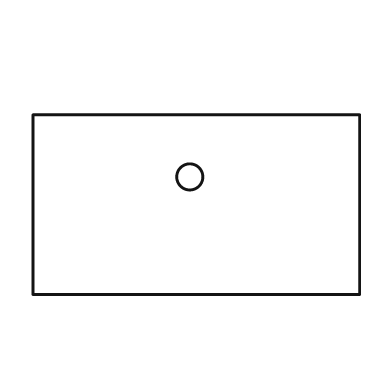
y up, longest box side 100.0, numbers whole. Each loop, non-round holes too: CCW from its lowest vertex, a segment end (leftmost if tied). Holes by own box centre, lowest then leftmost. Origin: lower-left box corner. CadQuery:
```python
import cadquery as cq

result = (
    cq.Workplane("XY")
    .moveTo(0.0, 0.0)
    .lineTo(100.0, 0.0)
    .lineTo(100.0, 55.0)
    .lineTo(0.0, 55.0)
    .close()
    .moveTo(48.0, 36.0)
    .circle(4.0)
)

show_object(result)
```